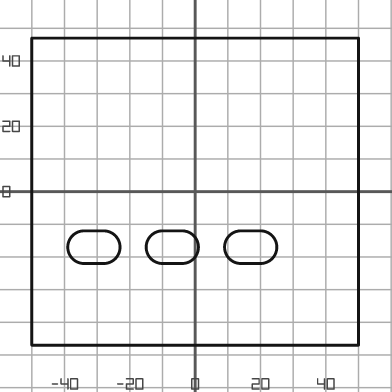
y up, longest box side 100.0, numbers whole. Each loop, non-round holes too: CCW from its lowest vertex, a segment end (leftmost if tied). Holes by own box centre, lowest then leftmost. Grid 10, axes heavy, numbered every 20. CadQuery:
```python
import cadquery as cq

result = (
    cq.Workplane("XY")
    .moveTo(-50.0, -47.0)
    .lineTo(50.0, -47.0)
    .lineTo(50.0, 47.0)
    .lineTo(-50.0, 47.0)
    .close()
    .moveTo(-34.0, -22.0)
    .lineTo(-28.0, -22.0)
    .threePointArc((-23.0, -17.0), (-28.0, -12.0))
    .lineTo(-34.0, -12.0)
    .threePointArc((-39.0, -17.0), (-34.0, -22.0))
    .close()
    .moveTo(-10.0, -22.0)
    .lineTo(-4.0, -22.0)
    .threePointArc((1.0, -17.0), (-4.0, -12.0))
    .lineTo(-10.0, -12.0)
    .threePointArc((-15.0, -17.0), (-10.0, -22.0))
    .close()
    .moveTo(14.0, -22.0)
    .lineTo(20.0, -22.0)
    .threePointArc((25.0, -17.0), (20.0, -12.0))
    .lineTo(14.0, -12.0)
    .threePointArc((9.0, -17.0), (14.0, -22.0))
    .close()
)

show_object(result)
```